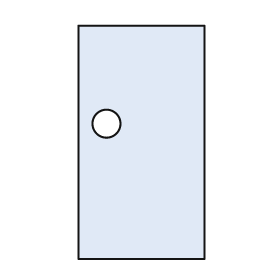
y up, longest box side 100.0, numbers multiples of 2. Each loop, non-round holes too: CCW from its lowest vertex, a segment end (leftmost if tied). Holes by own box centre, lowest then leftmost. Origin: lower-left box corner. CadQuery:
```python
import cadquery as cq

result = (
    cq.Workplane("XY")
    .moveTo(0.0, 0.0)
    .lineTo(54.0, 0.0)
    .lineTo(54.0, 100.0)
    .lineTo(0.0, 100.0)
    .close()
    .moveTo(12.0, 58.0)
    .circle(6.0)
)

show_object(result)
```